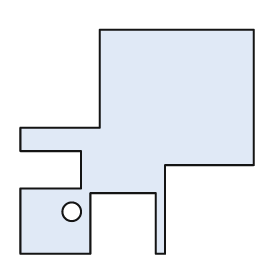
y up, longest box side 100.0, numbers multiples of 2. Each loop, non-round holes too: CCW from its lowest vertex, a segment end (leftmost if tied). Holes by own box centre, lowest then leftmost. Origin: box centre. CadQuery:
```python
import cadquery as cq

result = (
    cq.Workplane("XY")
    .moveTo(-50.0, -48.0)
    .lineTo(-20.0, -48.0)
    .lineTo(-20.0, -22.0)
    .lineTo(8.0, -22.0)
    .lineTo(8.0, -48.0)
    .lineTo(12.0, -48.0)
    .lineTo(12.0, -10.0)
    .lineTo(50.0, -10.0)
    .lineTo(50.0, 48.0)
    .lineTo(-16.0, 48.0)
    .lineTo(-16.0, 6.0)
    .lineTo(-50.0, 6.0)
    .lineTo(-50.0, -4.0)
    .lineTo(-24.0, -4.0)
    .lineTo(-24.0, -20.0)
    .lineTo(-50.0, -20.0)
    .close()
    .moveTo(-28.0, -30.0)
    .circle(4.0)
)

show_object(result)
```